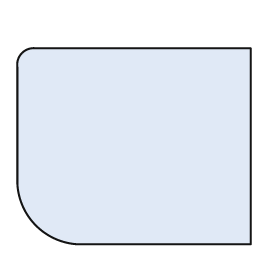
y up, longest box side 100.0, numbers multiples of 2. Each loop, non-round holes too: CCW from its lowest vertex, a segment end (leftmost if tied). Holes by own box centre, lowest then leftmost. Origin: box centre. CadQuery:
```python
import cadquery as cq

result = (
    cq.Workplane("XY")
    .moveTo(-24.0, -42.0)
    .lineTo(50.0, -42.0)
    .lineTo(50.0, 42.0)
    .lineTo(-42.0, 42.0)
    .threePointArc((-48.0, 40.0), (-50.0, 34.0))
    .lineTo(-50.0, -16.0)
    .threePointArc((-42.0, -34.0), (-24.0, -42.0))
    .close()
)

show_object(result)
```